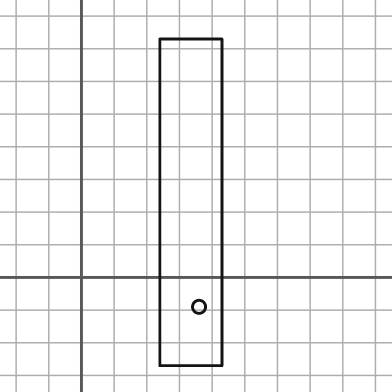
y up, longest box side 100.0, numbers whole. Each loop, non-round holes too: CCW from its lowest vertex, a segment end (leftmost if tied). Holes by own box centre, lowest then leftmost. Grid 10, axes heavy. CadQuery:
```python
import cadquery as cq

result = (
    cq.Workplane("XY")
    .moveTo(24.0, -27.0)
    .lineTo(43.0, -27.0)
    .lineTo(43.0, 73.0)
    .lineTo(24.0, 73.0)
    .close()
    .moveTo(36.0, -9.0)
    .circle(2.0)
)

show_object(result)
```